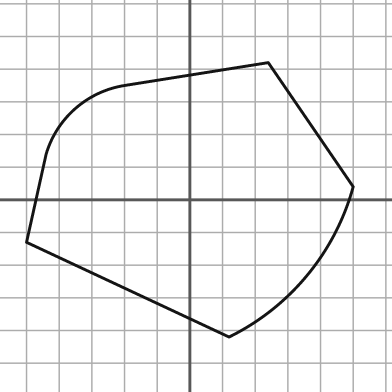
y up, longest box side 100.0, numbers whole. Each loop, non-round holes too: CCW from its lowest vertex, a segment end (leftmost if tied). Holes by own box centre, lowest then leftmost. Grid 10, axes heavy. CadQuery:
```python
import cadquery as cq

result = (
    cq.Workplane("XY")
    .moveTo(12.0, -42.0)
    .threePointArc((36.0, -23.0), (50.0, 4.0))
    .lineTo(24.0, 42.0)
    .lineTo(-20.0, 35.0)
    .threePointArc((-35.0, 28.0), (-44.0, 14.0))
    .lineTo(-50.0, -13.0)
    .close()
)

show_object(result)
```